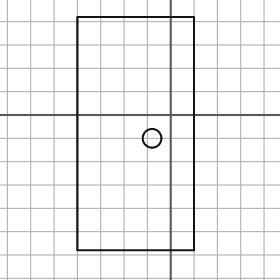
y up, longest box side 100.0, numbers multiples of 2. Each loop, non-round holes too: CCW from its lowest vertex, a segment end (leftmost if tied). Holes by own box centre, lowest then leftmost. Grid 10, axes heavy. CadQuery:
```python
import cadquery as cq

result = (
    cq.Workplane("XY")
    .moveTo(-40.0, -58.0)
    .lineTo(10.0, -58.0)
    .lineTo(10.0, 42.0)
    .lineTo(-40.0, 42.0)
    .close()
    .moveTo(-8.0, -10.0)
    .circle(4.0)
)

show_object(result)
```